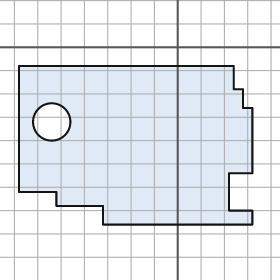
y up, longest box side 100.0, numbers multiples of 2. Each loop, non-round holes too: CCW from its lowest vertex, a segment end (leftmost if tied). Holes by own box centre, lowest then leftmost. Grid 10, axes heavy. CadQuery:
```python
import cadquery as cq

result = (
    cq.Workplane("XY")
    .moveTo(-32.0, -76.0)
    .lineTo(32.0, -76.0)
    .lineTo(32.0, -70.0)
    .lineTo(22.0, -70.0)
    .lineTo(22.0, -54.0)
    .lineTo(32.0, -54.0)
    .lineTo(32.0, -26.0)
    .lineTo(28.0, -26.0)
    .lineTo(28.0, -18.0)
    .lineTo(24.0, -18.0)
    .lineTo(24.0, -8.0)
    .lineTo(-68.0, -8.0)
    .lineTo(-68.0, -62.0)
    .lineTo(-52.0, -62.0)
    .lineTo(-52.0, -68.0)
    .lineTo(-32.0, -68.0)
    .close()
    .moveTo(-54.0, -32.0)
    .circle(8.0)
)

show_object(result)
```